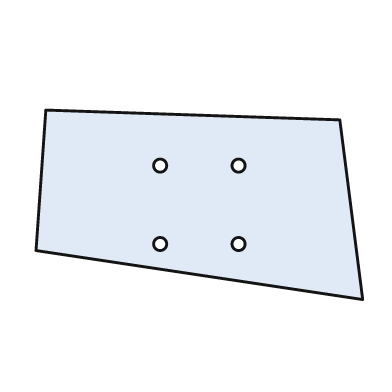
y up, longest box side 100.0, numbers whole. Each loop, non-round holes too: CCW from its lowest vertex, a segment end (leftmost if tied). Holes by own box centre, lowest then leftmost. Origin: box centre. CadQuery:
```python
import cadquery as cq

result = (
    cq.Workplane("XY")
    .moveTo(50.0, -29.0)
    .lineTo(43.0, 26.0)
    .lineTo(-47.0, 29.0)
    .lineTo(-50.0, -14.0)
    .close()
    .moveTo(-12.0, -12.0)
    .circle(2.0)
    .moveTo(12.0, -12.0)
    .circle(2.0)
    .moveTo(-12.0, 12.0)
    .circle(2.0)
    .moveTo(12.0, 12.0)
    .circle(2.0)
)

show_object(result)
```